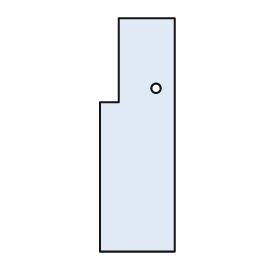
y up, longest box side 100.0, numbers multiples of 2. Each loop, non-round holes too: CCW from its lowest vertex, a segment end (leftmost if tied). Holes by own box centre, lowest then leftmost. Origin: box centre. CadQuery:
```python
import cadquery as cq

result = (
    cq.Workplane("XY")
    .moveTo(-16.0, -50.0)
    .lineTo(16.0, -50.0)
    .lineTo(16.0, 50.0)
    .lineTo(-8.0, 50.0)
    .lineTo(-8.0, 14.0)
    .lineTo(-16.0, 14.0)
    .close()
    .moveTo(8.0, 20.0)
    .circle(2.0)
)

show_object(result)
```